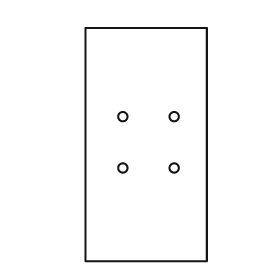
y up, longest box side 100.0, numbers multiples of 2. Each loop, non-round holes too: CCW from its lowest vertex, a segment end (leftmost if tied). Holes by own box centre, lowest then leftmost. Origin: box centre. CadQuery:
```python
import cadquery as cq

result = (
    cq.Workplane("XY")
    .moveTo(-26.0, -50.0)
    .lineTo(26.0, -50.0)
    .lineTo(26.0, 50.0)
    .lineTo(-26.0, 50.0)
    .close()
    .moveTo(-10.0, -10.0)
    .circle(2.0)
    .moveTo(12.0, -10.0)
    .circle(2.0)
    .moveTo(-10.0, 12.0)
    .circle(2.0)
    .moveTo(12.0, 12.0)
    .circle(2.0)
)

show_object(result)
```